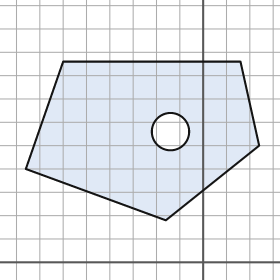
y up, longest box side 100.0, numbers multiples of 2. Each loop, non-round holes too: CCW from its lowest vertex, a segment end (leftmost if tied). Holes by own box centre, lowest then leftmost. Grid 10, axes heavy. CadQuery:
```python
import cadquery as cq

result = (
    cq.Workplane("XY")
    .moveTo(-16.0, 18.0)
    .lineTo(24.0, 50.0)
    .lineTo(16.0, 86.0)
    .lineTo(-60.0, 86.0)
    .lineTo(-76.0, 40.0)
    .close()
    .moveTo(-14.0, 56.0)
    .circle(8.0)
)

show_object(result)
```